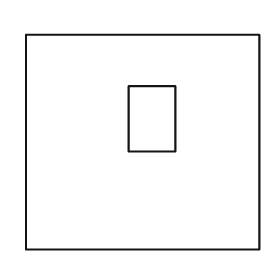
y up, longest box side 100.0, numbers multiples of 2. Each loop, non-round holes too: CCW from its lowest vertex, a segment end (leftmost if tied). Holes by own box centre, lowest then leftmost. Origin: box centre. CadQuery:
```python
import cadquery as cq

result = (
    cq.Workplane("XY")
    .moveTo(-50.0, -46.0)
    .lineTo(50.0, -46.0)
    .lineTo(50.0, 46.0)
    .lineTo(-50.0, 46.0)
    .close()
    .moveTo(-6.0, -4.0)
    .lineTo(14.0, -4.0)
    .lineTo(14.0, 24.0)
    .lineTo(-6.0, 24.0)
    .close()
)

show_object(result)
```